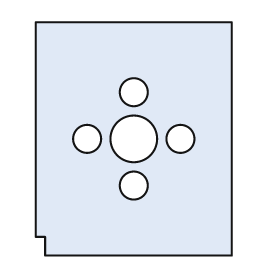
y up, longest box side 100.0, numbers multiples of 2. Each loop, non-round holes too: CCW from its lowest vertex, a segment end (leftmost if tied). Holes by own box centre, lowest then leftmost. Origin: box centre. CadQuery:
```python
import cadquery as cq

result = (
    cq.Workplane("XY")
    .moveTo(-38.0, -50.0)
    .lineTo(42.0, -50.0)
    .lineTo(42.0, 50.0)
    .lineTo(-42.0, 50.0)
    .lineTo(-42.0, -42.0)
    .lineTo(-38.0, -42.0)
    .close()
    .moveTo(0.0, -20.0)
    .circle(6.0)
    .moveTo(-20.0, 0.0)
    .circle(6.0)
    .moveTo(0.0, 0.0)
    .circle(10.0)
    .moveTo(20.0, 0.0)
    .circle(6.0)
    .moveTo(0.0, 20.0)
    .circle(6.0)
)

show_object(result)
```